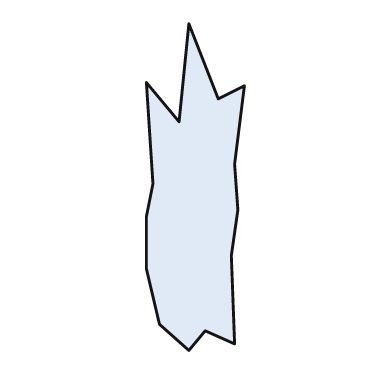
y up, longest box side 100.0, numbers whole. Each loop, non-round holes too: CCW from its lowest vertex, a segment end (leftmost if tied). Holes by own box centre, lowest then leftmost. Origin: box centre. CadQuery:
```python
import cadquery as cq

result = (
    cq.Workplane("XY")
    .moveTo(-2.0, -50.0)
    .lineTo(3.0, -44.0)
    .lineTo(12.0, -48.0)
    .lineTo(11.0, -21.0)
    .lineTo(13.0, -7.0)
    .lineTo(12.0, 7.0)
    .lineTo(15.0, 31.0)
    .lineTo(7.0, 27.0)
    .lineTo(-2.0, 50.0)
    .lineTo(-5.0, 20.0)
    .lineTo(-15.0, 32.0)
    .lineTo(-13.0, 1.0)
    .lineTo(-15.0, -9.0)
    .lineTo(-15.0, -25.0)
    .lineTo(-11.0, -42.0)
    .close()
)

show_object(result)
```